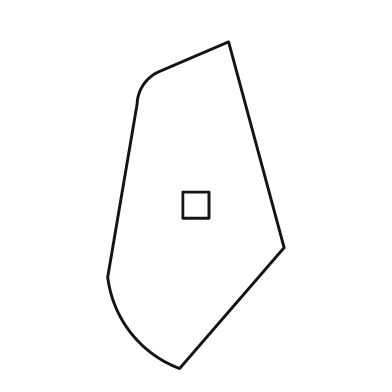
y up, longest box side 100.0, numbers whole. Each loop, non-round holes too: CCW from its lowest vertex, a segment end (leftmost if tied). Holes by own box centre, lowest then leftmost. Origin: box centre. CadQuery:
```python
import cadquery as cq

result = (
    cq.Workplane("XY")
    .moveTo(-5.0, -50.0)
    .lineTo(27.0, -13.0)
    .lineTo(10.0, 50.0)
    .lineTo(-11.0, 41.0)
    .threePointArc((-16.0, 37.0), (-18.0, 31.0))
    .lineTo(-27.0, -22.0)
    .threePointArc((-20.0, -39.0), (-5.0, -50.0))
    .close()
    .moveTo(-4.0, -4.0)
    .lineTo(4.0, -4.0)
    .lineTo(4.0, 4.0)
    .lineTo(-4.0, 4.0)
    .close()
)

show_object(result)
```